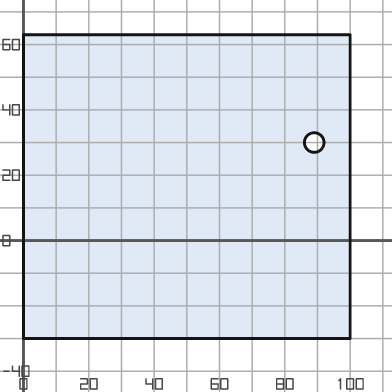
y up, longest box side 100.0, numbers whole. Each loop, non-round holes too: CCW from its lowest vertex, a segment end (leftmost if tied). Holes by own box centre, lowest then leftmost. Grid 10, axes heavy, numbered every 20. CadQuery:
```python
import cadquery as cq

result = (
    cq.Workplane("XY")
    .moveTo(0.0, -30.0)
    .lineTo(100.0, -30.0)
    .lineTo(100.0, 63.0)
    .lineTo(0.0, 63.0)
    .close()
    .moveTo(89.0, 30.0)
    .circle(3.0)
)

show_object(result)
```